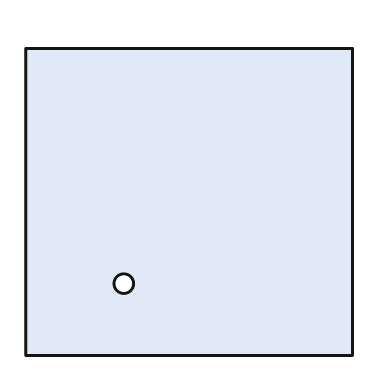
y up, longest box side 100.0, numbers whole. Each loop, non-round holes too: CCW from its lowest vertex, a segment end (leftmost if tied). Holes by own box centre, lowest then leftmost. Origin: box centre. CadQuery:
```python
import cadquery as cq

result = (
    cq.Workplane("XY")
    .moveTo(-50.0, -47.0)
    .lineTo(50.0, -47.0)
    .lineTo(50.0, 47.0)
    .lineTo(-50.0, 47.0)
    .close()
    .moveTo(-20.0, -25.0)
    .circle(3.0)
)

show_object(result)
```